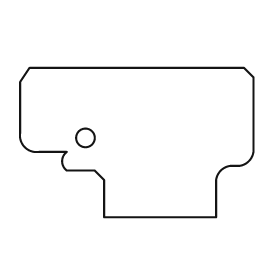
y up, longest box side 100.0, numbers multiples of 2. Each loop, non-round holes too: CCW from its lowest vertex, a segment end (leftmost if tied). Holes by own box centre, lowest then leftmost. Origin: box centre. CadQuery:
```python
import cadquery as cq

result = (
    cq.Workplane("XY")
    .moveTo(-14.0, -32.0)
    .lineTo(34.0, -32.0)
    .lineTo(34.0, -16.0)
    .threePointArc((36.0, -12.0), (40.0, -10.0))
    .lineTo(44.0, -10.0)
    .threePointArc((48.0, -8.0), (50.0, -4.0))
    .lineTo(50.0, 28.0)
    .lineTo(46.0, 32.0)
    .lineTo(-46.0, 32.0)
    .lineTo(-50.0, 26.0)
    .lineTo(-50.0, 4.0)
    .threePointArc((-48.0, -2.0), (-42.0, -4.0))
    .lineTo(-30.0, -4.0)
    .threePointArc((-32.0, -8.0), (-30.0, -12.0))
    .lineTo(-18.0, -12.0)
    .lineTo(-14.0, -16.0)
    .close()
    .moveTo(-22.0, 2.0)
    .circle(4.0)
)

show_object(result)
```